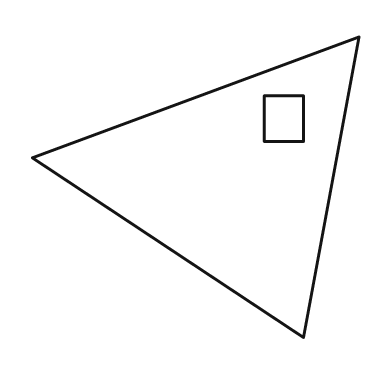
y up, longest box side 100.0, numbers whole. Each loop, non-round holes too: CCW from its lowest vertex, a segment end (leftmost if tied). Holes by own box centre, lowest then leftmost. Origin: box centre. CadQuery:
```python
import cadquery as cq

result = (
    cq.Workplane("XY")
    .moveTo(33.0, -46.0)
    .lineTo(50.0, 46.0)
    .lineTo(-50.0, 9.0)
    .close()
    .moveTo(21.0, 14.0)
    .lineTo(33.0, 14.0)
    .lineTo(33.0, 28.0)
    .lineTo(21.0, 28.0)
    .close()
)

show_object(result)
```